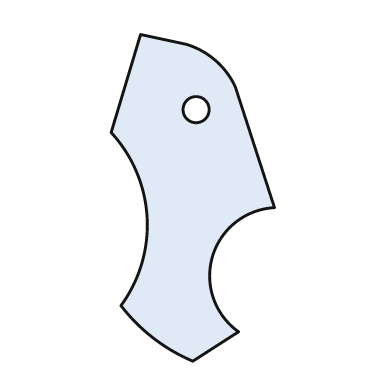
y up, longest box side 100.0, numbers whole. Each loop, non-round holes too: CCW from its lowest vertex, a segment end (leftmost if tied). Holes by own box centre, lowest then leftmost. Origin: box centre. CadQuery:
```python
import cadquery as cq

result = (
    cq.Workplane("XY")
    .moveTo(0.0, -50.0)
    .lineTo(14.0, -41.0)
    .threePointArc((6.0, -18.0), (25.0, -3.0))
    .lineTo(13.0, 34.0)
    .threePointArc((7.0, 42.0), (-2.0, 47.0))
    .lineTo(-16.0, 50.0)
    .lineTo(-25.0, 20.0)
    .threePointArc((-14.0, -6.0), (-22.0, -33.0))
    .threePointArc((-12.0, -43.0), (0.0, -50.0))
    .close()
    .moveTo(1.0, 27.0)
    .circle(4.0)
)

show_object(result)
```